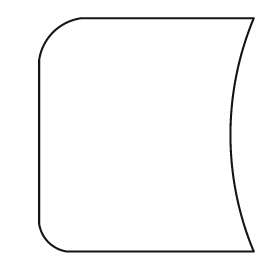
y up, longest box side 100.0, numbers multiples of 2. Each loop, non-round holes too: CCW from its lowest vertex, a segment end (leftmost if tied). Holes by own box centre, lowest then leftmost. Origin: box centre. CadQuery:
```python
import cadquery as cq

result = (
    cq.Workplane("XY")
    .moveTo(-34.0, -50.0)
    .lineTo(46.0, -50.0)
    .threePointArc((36.0, 0.0), (46.0, 50.0))
    .lineTo(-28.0, 50.0)
    .threePointArc((-40.0, 44.0), (-46.0, 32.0))
    .lineTo(-46.0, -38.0)
    .threePointArc((-42.0, -46.0), (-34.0, -50.0))
    .close()
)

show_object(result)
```